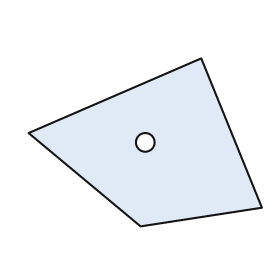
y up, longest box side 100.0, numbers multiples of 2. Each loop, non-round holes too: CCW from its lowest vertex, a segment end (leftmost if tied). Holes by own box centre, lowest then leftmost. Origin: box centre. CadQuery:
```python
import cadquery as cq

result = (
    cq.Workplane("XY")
    .moveTo(-2.0, -36.0)
    .lineTo(50.0, -28.0)
    .lineTo(24.0, 36.0)
    .lineTo(-50.0, 4.0)
    .close()
    .moveTo(0.0, 0.0)
    .circle(4.0)
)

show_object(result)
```